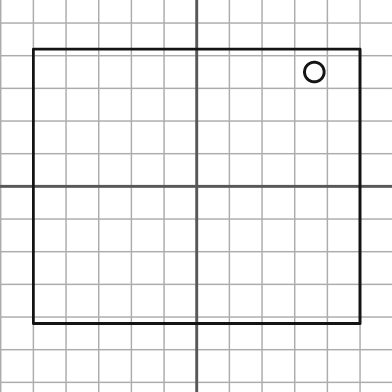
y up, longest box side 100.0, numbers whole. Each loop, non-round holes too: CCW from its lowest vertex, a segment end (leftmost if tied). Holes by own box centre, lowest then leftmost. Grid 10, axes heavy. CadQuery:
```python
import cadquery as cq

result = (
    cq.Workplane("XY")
    .moveTo(-50.0, -42.0)
    .lineTo(50.0, -42.0)
    .lineTo(50.0, 42.0)
    .lineTo(-50.0, 42.0)
    .close()
    .moveTo(36.0, 35.0)
    .circle(3.0)
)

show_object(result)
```